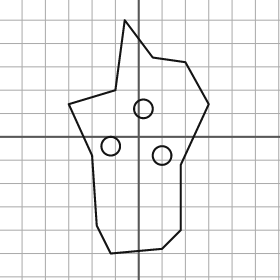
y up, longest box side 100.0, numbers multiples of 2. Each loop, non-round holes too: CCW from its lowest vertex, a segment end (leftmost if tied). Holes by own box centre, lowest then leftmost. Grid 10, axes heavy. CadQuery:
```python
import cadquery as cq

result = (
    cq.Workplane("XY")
    .moveTo(-12.0, -50.0)
    .lineTo(10.0, -48.0)
    .lineTo(18.0, -40.0)
    .lineTo(18.0, -12.0)
    .lineTo(30.0, 14.0)
    .lineTo(20.0, 32.0)
    .lineTo(6.0, 34.0)
    .lineTo(-6.0, 50.0)
    .lineTo(-10.0, 20.0)
    .lineTo(-30.0, 14.0)
    .lineTo(-20.0, -8.0)
    .lineTo(-18.0, -38.0)
    .close()
    .moveTo(10.0, -8.0)
    .circle(4.0)
    .moveTo(-12.0, -4.0)
    .circle(4.0)
    .moveTo(2.0, 12.0)
    .circle(4.0)
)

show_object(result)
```